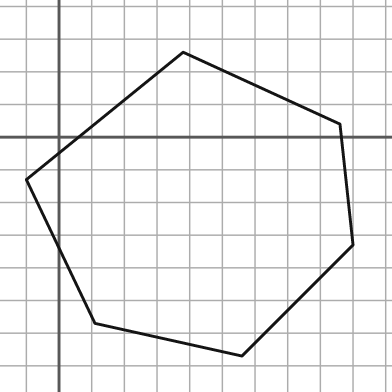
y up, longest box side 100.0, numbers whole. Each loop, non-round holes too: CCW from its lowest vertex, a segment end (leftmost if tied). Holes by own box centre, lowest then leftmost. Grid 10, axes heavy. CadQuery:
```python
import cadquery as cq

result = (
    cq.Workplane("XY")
    .moveTo(56.0, -67.0)
    .lineTo(90.0, -33.0)
    .lineTo(86.0, 4.0)
    .lineTo(38.0, 26.0)
    .lineTo(-10.0, -13.0)
    .lineTo(11.0, -57.0)
    .close()
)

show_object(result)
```